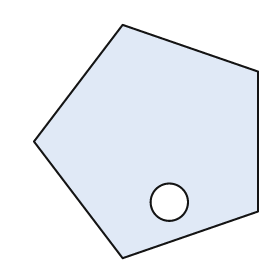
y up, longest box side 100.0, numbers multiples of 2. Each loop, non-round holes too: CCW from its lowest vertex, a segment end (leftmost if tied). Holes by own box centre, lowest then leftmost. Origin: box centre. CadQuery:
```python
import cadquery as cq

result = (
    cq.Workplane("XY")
    .moveTo(-10.0, -50.0)
    .lineTo(48.0, -30.0)
    .lineTo(48.0, 30.0)
    .lineTo(-10.0, 50.0)
    .lineTo(-48.0, 0.0)
    .close()
    .moveTo(10.0, -26.0)
    .circle(8.0)
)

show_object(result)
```